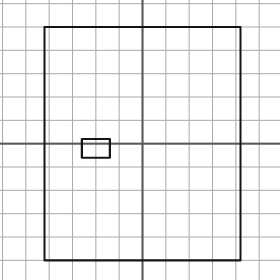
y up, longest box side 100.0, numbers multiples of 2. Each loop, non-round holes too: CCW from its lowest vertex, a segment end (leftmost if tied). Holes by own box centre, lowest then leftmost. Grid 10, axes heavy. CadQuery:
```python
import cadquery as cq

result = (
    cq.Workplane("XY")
    .moveTo(-42.0, -50.0)
    .lineTo(42.0, -50.0)
    .lineTo(42.0, 50.0)
    .lineTo(-42.0, 50.0)
    .close()
    .moveTo(-26.0, -6.0)
    .lineTo(-14.0, -6.0)
    .lineTo(-14.0, 2.0)
    .lineTo(-26.0, 2.0)
    .close()
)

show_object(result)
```